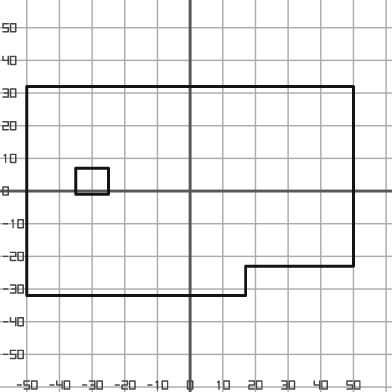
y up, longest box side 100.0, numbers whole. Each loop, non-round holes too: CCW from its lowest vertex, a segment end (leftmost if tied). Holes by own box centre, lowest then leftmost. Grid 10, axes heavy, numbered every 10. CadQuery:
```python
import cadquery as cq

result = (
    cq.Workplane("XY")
    .moveTo(-50.0, -32.0)
    .lineTo(17.0, -32.0)
    .lineTo(17.0, -23.0)
    .lineTo(50.0, -23.0)
    .lineTo(50.0, 32.0)
    .lineTo(-50.0, 32.0)
    .close()
    .moveTo(-35.0, -1.0)
    .lineTo(-25.0, -1.0)
    .lineTo(-25.0, 7.0)
    .lineTo(-35.0, 7.0)
    .close()
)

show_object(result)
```